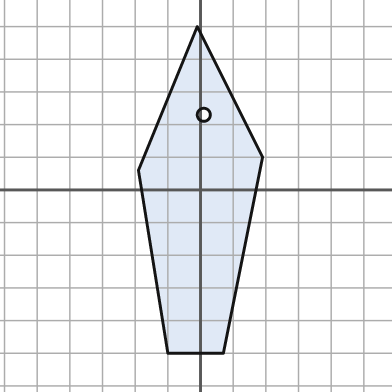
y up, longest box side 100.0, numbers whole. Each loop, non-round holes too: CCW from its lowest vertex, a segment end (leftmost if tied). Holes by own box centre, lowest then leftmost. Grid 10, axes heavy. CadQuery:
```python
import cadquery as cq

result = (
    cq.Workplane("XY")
    .moveTo(-10.0, -50.0)
    .lineTo(7.0, -50.0)
    .lineTo(19.0, 10.0)
    .lineTo(-1.0, 50.0)
    .lineTo(-19.0, 6.0)
    .close()
    .moveTo(1.0, 23.0)
    .circle(2.0)
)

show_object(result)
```